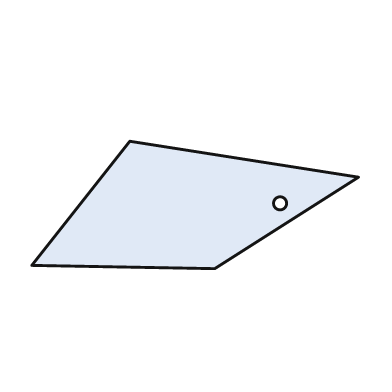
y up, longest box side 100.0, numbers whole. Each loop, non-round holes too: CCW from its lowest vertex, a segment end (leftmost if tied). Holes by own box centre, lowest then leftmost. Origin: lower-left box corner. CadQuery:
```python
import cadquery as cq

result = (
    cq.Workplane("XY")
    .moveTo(56.0, 0.0)
    .lineTo(100.0, 28.0)
    .lineTo(30.0, 39.0)
    .lineTo(0.0, 1.0)
    .close()
    .moveTo(76.0, 20.0)
    .circle(2.0)
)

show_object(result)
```